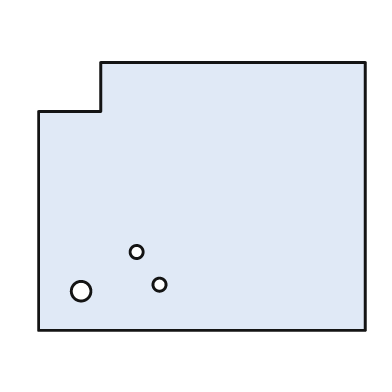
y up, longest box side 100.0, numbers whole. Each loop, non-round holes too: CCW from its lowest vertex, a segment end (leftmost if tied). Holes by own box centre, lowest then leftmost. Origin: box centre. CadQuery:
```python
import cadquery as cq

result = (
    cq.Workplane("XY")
    .moveTo(-50.0, -41.0)
    .lineTo(50.0, -41.0)
    .lineTo(50.0, 41.0)
    .lineTo(-31.0, 41.0)
    .lineTo(-31.0, 26.0)
    .lineTo(-50.0, 26.0)
    .close()
    .moveTo(-37.0, -29.0)
    .circle(3.0)
    .moveTo(-13.0, -27.0)
    .circle(2.0)
    .moveTo(-20.0, -17.0)
    .circle(2.0)
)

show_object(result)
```